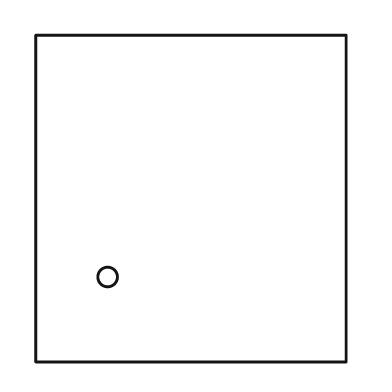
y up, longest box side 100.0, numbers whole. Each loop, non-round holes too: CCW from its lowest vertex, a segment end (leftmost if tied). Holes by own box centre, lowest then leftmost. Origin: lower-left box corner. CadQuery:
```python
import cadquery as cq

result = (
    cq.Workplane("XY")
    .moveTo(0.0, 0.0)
    .lineTo(95.0, 0.0)
    .lineTo(95.0, 100.0)
    .lineTo(0.0, 100.0)
    .close()
    .moveTo(22.0, 26.0)
    .circle(3.0)
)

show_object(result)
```